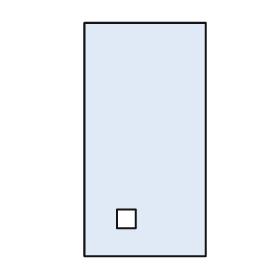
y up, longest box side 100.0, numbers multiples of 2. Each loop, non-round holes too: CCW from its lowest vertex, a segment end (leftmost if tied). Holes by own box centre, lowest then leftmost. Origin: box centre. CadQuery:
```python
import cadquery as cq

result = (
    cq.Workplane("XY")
    .moveTo(-26.0, -50.0)
    .lineTo(26.0, -50.0)
    .lineTo(26.0, 50.0)
    .lineTo(-26.0, 50.0)
    .close()
    .moveTo(-12.0, -38.0)
    .lineTo(-4.0, -38.0)
    .lineTo(-4.0, -30.0)
    .lineTo(-12.0, -30.0)
    .close()
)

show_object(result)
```